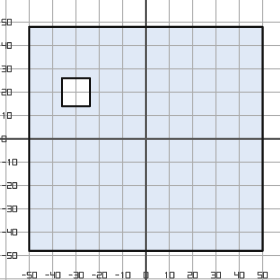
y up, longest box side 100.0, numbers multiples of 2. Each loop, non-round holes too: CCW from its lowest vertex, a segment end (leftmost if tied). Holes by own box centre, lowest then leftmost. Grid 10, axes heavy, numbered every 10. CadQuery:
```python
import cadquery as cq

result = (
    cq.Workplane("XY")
    .moveTo(-50.0, -48.0)
    .lineTo(50.0, -48.0)
    .lineTo(50.0, 48.0)
    .lineTo(-50.0, 48.0)
    .close()
    .moveTo(-36.0, 14.0)
    .lineTo(-24.0, 14.0)
    .lineTo(-24.0, 26.0)
    .lineTo(-36.0, 26.0)
    .close()
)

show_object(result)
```